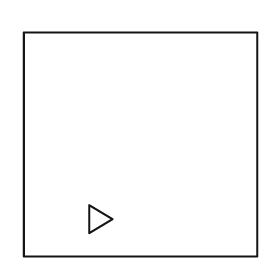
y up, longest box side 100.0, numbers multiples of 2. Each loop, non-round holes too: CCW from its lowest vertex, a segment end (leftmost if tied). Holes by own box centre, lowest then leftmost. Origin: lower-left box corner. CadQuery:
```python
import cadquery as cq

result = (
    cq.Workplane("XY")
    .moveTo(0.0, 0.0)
    .lineTo(100.0, 0.0)
    .lineTo(100.0, 96.0)
    .lineTo(0.0, 96.0)
    .close()
    .moveTo(28.0, 10.0)
    .lineTo(38.0, 16.0)
    .lineTo(28.0, 22.0)
    .close()
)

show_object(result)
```